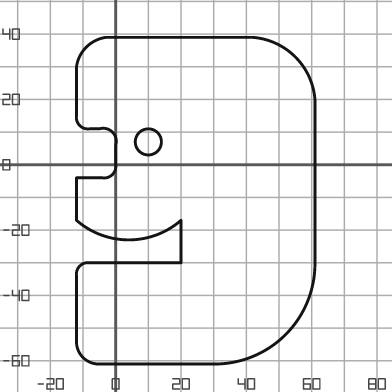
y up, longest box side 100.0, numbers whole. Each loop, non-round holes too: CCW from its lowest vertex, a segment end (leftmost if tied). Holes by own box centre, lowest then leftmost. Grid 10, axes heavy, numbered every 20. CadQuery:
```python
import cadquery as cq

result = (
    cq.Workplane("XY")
    .moveTo(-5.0, -61.0)
    .lineTo(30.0, -61.0)
    .threePointArc((52.0, -52.0), (61.0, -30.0))
    .lineTo(61.0, 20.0)
    .threePointArc((55.0, 33.0), (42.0, 39.0))
    .lineTo(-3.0, 39.0)
    .threePointArc((-9.0, 36.0), (-12.0, 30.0))
    .lineTo(-12.0, 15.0)
    .threePointArc((-11.0, 12.0), (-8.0, 11.0))
    .lineTo(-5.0, 11.0)
    .threePointArc((-1.0, 10.0), (0.0, 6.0))
    .lineTo(0.0, 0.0)
    .threePointArc((-1.0, -3.0), (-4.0, -4.0))
    .lineTo(-12.0, -4.0)
    .lineTo(-12.0, -17.0)
    .threePointArc((4.0, -23.0), (20.0, -17.0))
    .lineTo(20.0, -30.0)
    .lineTo(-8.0, -30.0)
    .threePointArc((-11.0, -31.0), (-12.0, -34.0))
    .lineTo(-12.0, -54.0)
    .threePointArc((-10.0, -59.0), (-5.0, -61.0))
    .close()
    .moveTo(10.0, 7.0)
    .circle(4.0)
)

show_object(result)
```